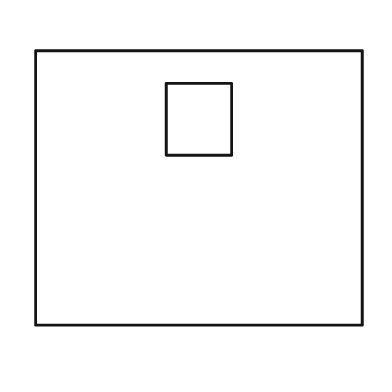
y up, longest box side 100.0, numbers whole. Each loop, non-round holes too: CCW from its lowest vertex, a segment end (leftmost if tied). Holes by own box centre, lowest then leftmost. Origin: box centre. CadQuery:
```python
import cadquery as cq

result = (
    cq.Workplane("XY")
    .moveTo(-50.0, -42.0)
    .lineTo(50.0, -42.0)
    .lineTo(50.0, 42.0)
    .lineTo(-50.0, 42.0)
    .close()
    .moveTo(-10.0, 10.0)
    .lineTo(10.0, 10.0)
    .lineTo(10.0, 32.0)
    .lineTo(-10.0, 32.0)
    .close()
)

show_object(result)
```